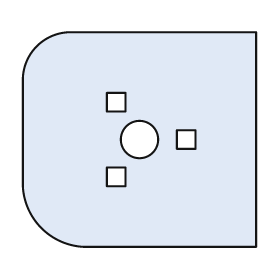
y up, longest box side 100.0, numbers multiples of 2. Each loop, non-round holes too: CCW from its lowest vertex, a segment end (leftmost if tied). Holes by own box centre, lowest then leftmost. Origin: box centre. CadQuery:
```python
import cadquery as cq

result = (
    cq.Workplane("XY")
    .moveTo(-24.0, -46.0)
    .lineTo(50.0, -46.0)
    .lineTo(50.0, 46.0)
    .lineTo(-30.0, 46.0)
    .threePointArc((-44.0, 40.0), (-50.0, 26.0))
    .lineTo(-50.0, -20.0)
    .threePointArc((-42.0, -38.0), (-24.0, -46.0))
    .close()
    .moveTo(-14.0, -20.0)
    .lineTo(-6.0, -20.0)
    .lineTo(-6.0, -12.0)
    .lineTo(-14.0, -12.0)
    .close()
    .moveTo(0.0, 0.0)
    .circle(8.0)
    .moveTo(16.0, -4.0)
    .lineTo(24.0, -4.0)
    .lineTo(24.0, 4.0)
    .lineTo(16.0, 4.0)
    .close()
    .moveTo(-14.0, 12.0)
    .lineTo(-6.0, 12.0)
    .lineTo(-6.0, 20.0)
    .lineTo(-14.0, 20.0)
    .close()
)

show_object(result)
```